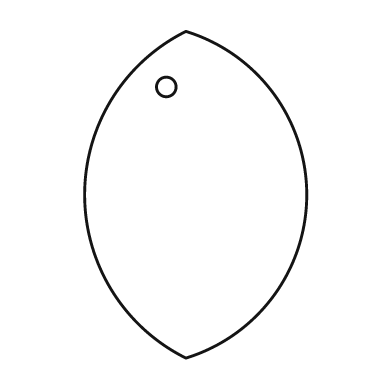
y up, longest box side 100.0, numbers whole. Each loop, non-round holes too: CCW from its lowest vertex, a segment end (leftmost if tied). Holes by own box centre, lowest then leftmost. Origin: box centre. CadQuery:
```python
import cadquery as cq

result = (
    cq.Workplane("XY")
    .moveTo(-3.0, -50.0)
    .threePointArc((34.0, 0.0), (-3.0, 50.0))
    .threePointArc((-34.0, 0.0), (-3.0, -50.0))
    .close()
    .moveTo(-9.0, 33.0)
    .circle(3.0)
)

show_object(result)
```